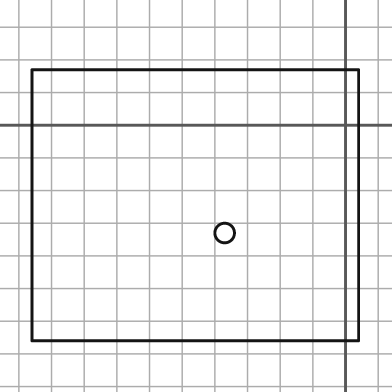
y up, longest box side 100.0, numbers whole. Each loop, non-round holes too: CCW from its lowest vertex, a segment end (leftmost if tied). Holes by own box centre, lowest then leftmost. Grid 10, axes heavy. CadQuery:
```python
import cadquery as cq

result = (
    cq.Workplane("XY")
    .moveTo(-96.0, -66.0)
    .lineTo(4.0, -66.0)
    .lineTo(4.0, 17.0)
    .lineTo(-96.0, 17.0)
    .close()
    .moveTo(-37.0, -33.0)
    .circle(3.0)
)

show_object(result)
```